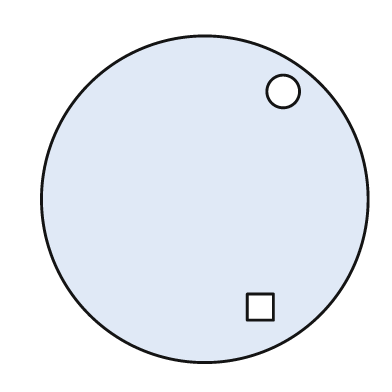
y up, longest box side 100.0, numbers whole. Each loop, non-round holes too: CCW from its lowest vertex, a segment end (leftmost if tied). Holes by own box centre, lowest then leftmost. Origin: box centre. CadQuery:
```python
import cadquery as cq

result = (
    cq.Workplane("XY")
    .moveTo(0.0, 0.0)
    .circle(50.0)
    .moveTo(13.0, -37.0)
    .lineTo(21.0, -37.0)
    .lineTo(21.0, -29.0)
    .lineTo(13.0, -29.0)
    .close()
    .moveTo(24.0, 33.0)
    .circle(5.0)
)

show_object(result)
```